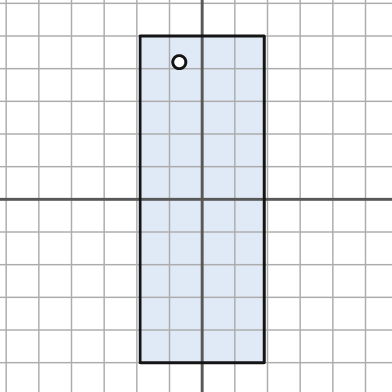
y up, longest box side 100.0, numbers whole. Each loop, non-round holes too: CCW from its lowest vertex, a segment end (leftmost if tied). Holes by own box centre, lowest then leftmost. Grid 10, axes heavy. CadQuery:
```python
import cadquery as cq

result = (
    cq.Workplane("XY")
    .moveTo(-19.0, -50.0)
    .lineTo(19.0, -50.0)
    .lineTo(19.0, 50.0)
    .lineTo(-19.0, 50.0)
    .close()
    .moveTo(-7.0, 42.0)
    .circle(2.0)
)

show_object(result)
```